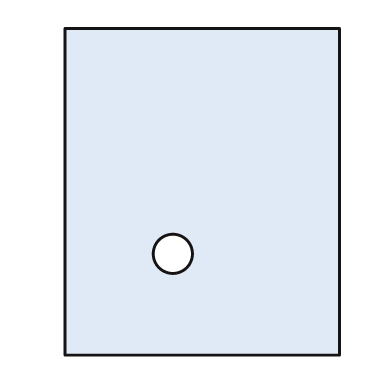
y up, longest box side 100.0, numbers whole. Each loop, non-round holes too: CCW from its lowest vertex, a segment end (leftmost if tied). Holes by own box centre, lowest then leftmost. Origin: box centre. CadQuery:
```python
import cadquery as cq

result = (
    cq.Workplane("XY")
    .moveTo(-42.0, -50.0)
    .lineTo(42.0, -50.0)
    .lineTo(42.0, 50.0)
    .lineTo(-42.0, 50.0)
    .close()
    .moveTo(-9.0, -19.0)
    .circle(6.0)
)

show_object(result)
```